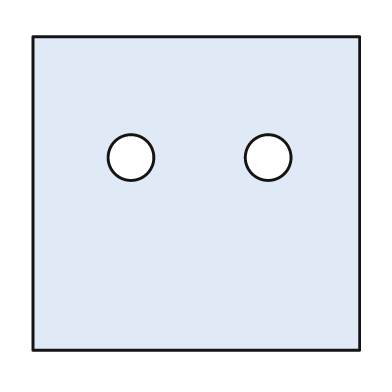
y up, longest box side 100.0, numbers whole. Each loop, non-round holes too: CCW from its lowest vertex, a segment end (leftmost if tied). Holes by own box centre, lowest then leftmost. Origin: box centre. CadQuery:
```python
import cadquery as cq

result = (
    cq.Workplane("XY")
    .moveTo(-50.0, -48.0)
    .lineTo(50.0, -48.0)
    .lineTo(50.0, 48.0)
    .lineTo(-50.0, 48.0)
    .close()
    .moveTo(-20.0, 11.0)
    .circle(7.0)
    .moveTo(22.0, 11.0)
    .circle(7.0)
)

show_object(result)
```